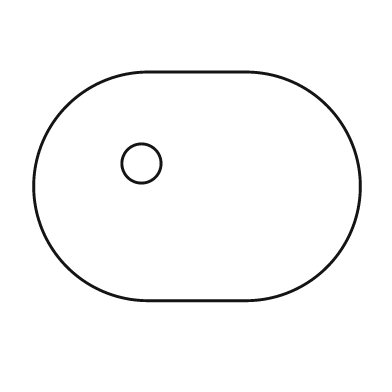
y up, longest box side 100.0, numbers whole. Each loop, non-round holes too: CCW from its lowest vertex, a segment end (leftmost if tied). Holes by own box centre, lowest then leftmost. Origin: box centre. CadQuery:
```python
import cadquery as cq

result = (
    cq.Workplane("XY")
    .moveTo(-15.0, -35.0)
    .lineTo(15.0, -35.0)
    .threePointArc((50.0, 0.0), (15.0, 35.0))
    .lineTo(-15.0, 35.0)
    .threePointArc((-50.0, 0.0), (-15.0, -35.0))
    .close()
    .moveTo(-17.0, 7.0)
    .circle(6.0)
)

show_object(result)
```